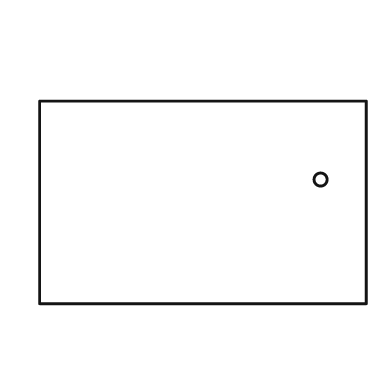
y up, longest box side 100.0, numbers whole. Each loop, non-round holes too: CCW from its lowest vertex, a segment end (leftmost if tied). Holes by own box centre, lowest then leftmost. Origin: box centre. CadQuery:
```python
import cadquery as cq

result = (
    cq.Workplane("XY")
    .moveTo(-50.0, -31.0)
    .lineTo(50.0, -31.0)
    .lineTo(50.0, 31.0)
    .lineTo(-50.0, 31.0)
    .close()
    .moveTo(36.0, 7.0)
    .circle(2.0)
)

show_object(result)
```